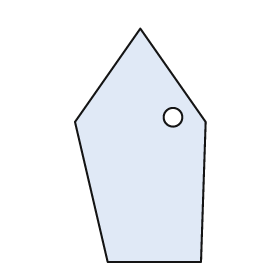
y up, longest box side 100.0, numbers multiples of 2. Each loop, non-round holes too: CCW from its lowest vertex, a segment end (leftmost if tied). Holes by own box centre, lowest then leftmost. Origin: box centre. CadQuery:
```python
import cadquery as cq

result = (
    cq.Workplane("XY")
    .moveTo(-14.0, -50.0)
    .lineTo(26.0, -50.0)
    .lineTo(28.0, 10.0)
    .lineTo(0.0, 50.0)
    .lineTo(-28.0, 10.0)
    .close()
    .moveTo(14.0, 12.0)
    .circle(4.0)
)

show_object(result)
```